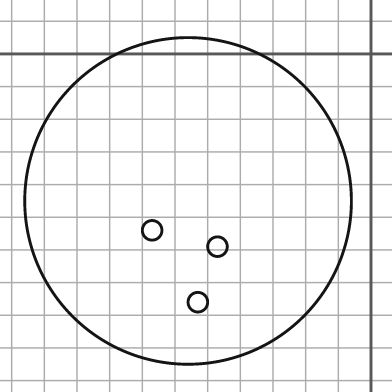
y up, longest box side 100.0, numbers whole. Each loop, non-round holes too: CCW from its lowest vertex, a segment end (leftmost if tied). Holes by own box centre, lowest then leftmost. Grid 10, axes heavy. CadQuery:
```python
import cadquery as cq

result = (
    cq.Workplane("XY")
    .moveTo(-56.0, -45.0)
    .circle(50.0)
    .moveTo(-53.0, -76.0)
    .circle(3.0)
    .moveTo(-47.0, -59.0)
    .circle(3.0)
    .moveTo(-67.0, -54.0)
    .circle(3.0)
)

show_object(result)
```